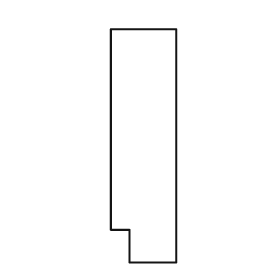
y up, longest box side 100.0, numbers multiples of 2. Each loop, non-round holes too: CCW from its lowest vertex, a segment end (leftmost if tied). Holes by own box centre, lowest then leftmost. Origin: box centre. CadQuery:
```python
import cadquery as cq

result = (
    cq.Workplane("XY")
    .moveTo(-6.0, -50.0)
    .lineTo(14.0, -50.0)
    .lineTo(14.0, 50.0)
    .lineTo(-14.0, 50.0)
    .lineTo(-14.0, -36.0)
    .lineTo(-6.0, -36.0)
    .close()
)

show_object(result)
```